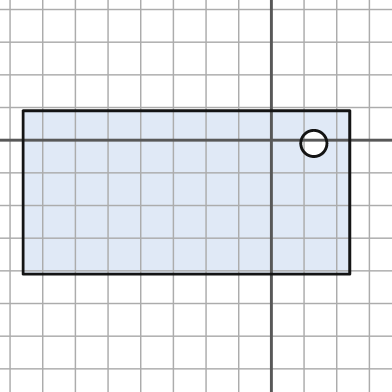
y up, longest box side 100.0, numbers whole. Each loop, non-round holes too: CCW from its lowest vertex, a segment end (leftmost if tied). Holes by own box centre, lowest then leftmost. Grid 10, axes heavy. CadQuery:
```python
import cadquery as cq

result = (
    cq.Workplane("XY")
    .moveTo(-76.0, -41.0)
    .lineTo(24.0, -41.0)
    .lineTo(24.0, 9.0)
    .lineTo(-76.0, 9.0)
    .close()
    .moveTo(13.0, -1.0)
    .circle(4.0)
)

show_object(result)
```